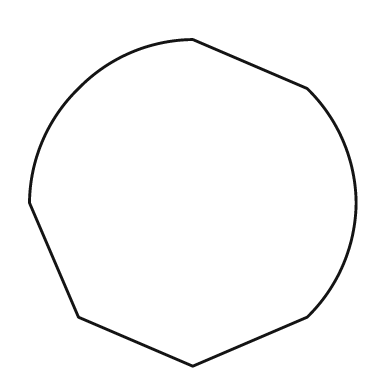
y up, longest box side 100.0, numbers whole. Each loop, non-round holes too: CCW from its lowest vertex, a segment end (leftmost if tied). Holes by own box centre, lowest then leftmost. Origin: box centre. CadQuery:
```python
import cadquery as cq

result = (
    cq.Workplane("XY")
    .moveTo(0.0, -50.0)
    .lineTo(35.0, -35.0)
    .threePointArc((46.0, -19.0), (50.0, 0.0))
    .threePointArc((46.0, 19.0), (35.0, 35.0))
    .lineTo(0.0, 50.0)
    .threePointArc((-19.0, 46.0), (-35.0, 35.0))
    .threePointArc((-46.0, 19.0), (-50.0, 0.0))
    .lineTo(-35.0, -35.0)
    .close()
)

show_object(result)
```